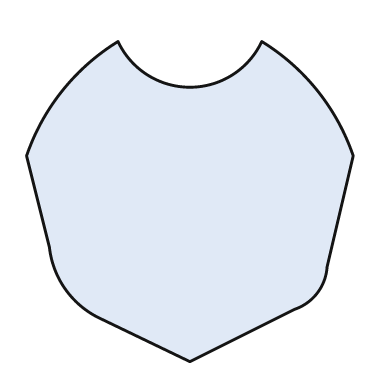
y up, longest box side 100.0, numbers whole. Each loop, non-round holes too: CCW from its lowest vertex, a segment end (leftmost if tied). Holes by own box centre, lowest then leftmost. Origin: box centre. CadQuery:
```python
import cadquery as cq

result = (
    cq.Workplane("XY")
    .moveTo(0.0, -49.0)
    .lineTo(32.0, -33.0)
    .threePointArc((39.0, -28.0), (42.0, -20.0))
    .lineTo(50.0, 14.0)
    .threePointArc((39.0, 34.0), (22.0, 49.0))
    .threePointArc((0.0, 35.0), (-22.0, 49.0))
    .threePointArc((-39.0, 34.0), (-50.0, 14.0))
    .lineTo(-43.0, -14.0)
    .threePointArc((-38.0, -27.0), (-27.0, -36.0))
    .close()
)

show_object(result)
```